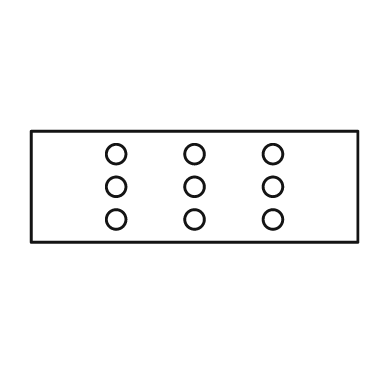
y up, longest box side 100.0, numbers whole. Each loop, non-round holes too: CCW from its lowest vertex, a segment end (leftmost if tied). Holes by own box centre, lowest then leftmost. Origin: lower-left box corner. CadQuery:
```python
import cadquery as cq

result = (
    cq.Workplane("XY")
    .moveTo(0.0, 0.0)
    .lineTo(100.0, 0.0)
    .lineTo(100.0, 34.0)
    .lineTo(0.0, 34.0)
    .close()
    .moveTo(26.0, 7.0)
    .circle(3.0)
    .moveTo(50.0, 7.0)
    .circle(3.0)
    .moveTo(74.0, 7.0)
    .circle(3.0)
    .moveTo(26.0, 17.0)
    .circle(3.0)
    .moveTo(50.0, 17.0)
    .circle(3.0)
    .moveTo(74.0, 17.0)
    .circle(3.0)
    .moveTo(26.0, 27.0)
    .circle(3.0)
    .moveTo(50.0, 27.0)
    .circle(3.0)
    .moveTo(74.0, 27.0)
    .circle(3.0)
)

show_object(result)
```